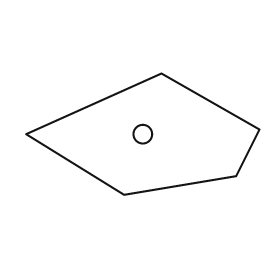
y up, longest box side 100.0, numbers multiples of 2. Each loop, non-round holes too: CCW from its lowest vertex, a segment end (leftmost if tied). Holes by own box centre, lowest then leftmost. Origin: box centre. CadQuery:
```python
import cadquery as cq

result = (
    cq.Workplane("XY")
    .moveTo(-8.0, -26.0)
    .lineTo(40.0, -18.0)
    .lineTo(50.0, 2.0)
    .lineTo(8.0, 26.0)
    .lineTo(-50.0, 0.0)
    .close()
    .moveTo(0.0, 0.0)
    .circle(4.0)
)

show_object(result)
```